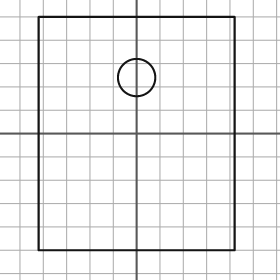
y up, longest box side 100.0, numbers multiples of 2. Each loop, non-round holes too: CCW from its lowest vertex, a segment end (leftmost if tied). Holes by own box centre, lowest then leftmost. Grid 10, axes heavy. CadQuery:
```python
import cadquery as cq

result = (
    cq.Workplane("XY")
    .moveTo(-42.0, -50.0)
    .lineTo(42.0, -50.0)
    .lineTo(42.0, 50.0)
    .lineTo(-42.0, 50.0)
    .close()
    .moveTo(0.0, 24.0)
    .circle(8.0)
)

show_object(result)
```